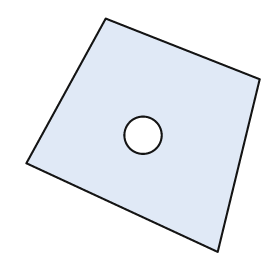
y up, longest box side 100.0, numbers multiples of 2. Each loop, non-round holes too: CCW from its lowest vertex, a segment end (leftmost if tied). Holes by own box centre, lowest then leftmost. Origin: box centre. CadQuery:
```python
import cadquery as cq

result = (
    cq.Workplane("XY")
    .moveTo(32.0, -50.0)
    .lineTo(50.0, 24.0)
    .lineTo(-16.0, 50.0)
    .lineTo(-50.0, -12.0)
    .close()
    .moveTo(0.0, 0.0)
    .circle(8.0)
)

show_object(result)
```